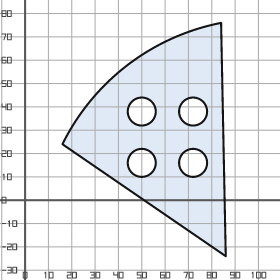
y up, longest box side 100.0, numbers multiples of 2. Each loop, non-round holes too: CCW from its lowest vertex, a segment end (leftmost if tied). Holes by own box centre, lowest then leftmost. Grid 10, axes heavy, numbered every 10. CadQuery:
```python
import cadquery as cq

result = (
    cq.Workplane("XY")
    .moveTo(86.0, -24.0)
    .lineTo(84.0, 76.0)
    .threePointArc((44.0, 58.0), (16.0, 24.0))
    .close()
    .moveTo(50.0, 16.0)
    .circle(6.0)
    .moveTo(72.0, 16.0)
    .circle(6.0)
    .moveTo(50.0, 38.0)
    .circle(6.0)
    .moveTo(72.0, 38.0)
    .circle(6.0)
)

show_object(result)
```